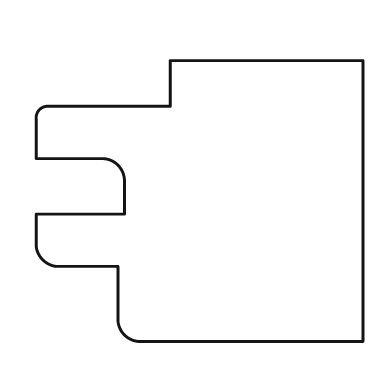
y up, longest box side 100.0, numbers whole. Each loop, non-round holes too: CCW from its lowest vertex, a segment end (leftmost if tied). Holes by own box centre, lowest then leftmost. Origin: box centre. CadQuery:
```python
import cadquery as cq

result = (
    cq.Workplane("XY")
    .moveTo(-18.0, -43.0)
    .lineTo(50.0, -43.0)
    .lineTo(50.0, 43.0)
    .lineTo(-9.0, 43.0)
    .lineTo(-9.0, 29.0)
    .lineTo(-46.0, 29.0)
    .threePointArc((-49.0, 28.0), (-50.0, 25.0))
    .lineTo(-50.0, 13.0)
    .lineTo(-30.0, 13.0)
    .threePointArc((-25.0, 11.0), (-23.0, 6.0))
    .lineTo(-23.0, -4.0)
    .lineTo(-50.0, -4.0)
    .lineTo(-50.0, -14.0)
    .threePointArc((-48.0, -18.0), (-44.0, -20.0))
    .lineTo(-25.0, -20.0)
    .lineTo(-25.0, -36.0)
    .threePointArc((-23.0, -41.0), (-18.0, -43.0))
    .close()
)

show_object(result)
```